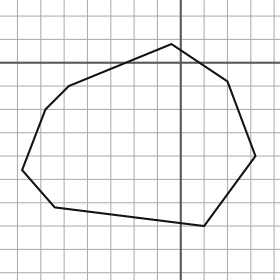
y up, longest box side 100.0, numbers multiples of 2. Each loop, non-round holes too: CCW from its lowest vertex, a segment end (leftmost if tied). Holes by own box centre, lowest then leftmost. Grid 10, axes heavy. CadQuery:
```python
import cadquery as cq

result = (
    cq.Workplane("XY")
    .moveTo(10.0, -70.0)
    .lineTo(32.0, -40.0)
    .lineTo(20.0, -8.0)
    .lineTo(-4.0, 8.0)
    .lineTo(-48.0, -10.0)
    .lineTo(-58.0, -20.0)
    .lineTo(-68.0, -46.0)
    .lineTo(-54.0, -62.0)
    .close()
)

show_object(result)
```